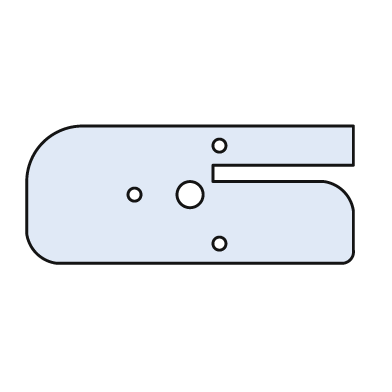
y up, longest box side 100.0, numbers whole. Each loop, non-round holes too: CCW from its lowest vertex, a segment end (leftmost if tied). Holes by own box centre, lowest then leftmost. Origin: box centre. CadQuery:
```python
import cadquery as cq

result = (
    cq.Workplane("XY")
    .moveTo(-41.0, -21.0)
    .lineTo(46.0, -21.0)
    .threePointArc((49.0, -20.0), (50.0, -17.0))
    .lineTo(50.0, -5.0)
    .threePointArc((47.0, 1.0), (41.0, 4.0))
    .lineTo(7.0, 4.0)
    .lineTo(7.0, 9.0)
    .lineTo(50.0, 9.0)
    .lineTo(50.0, 21.0)
    .lineTo(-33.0, 21.0)
    .threePointArc((-45.0, 16.0), (-50.0, 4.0))
    .lineTo(-50.0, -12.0)
    .threePointArc((-47.0, -18.0), (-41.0, -21.0))
    .close()
    .moveTo(9.0, -15.0)
    .circle(2.0)
    .moveTo(-17.0, 0.0)
    .circle(2.0)
    .moveTo(0.0, 0.0)
    .circle(4.0)
    .moveTo(9.0, 15.0)
    .circle(2.0)
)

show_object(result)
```